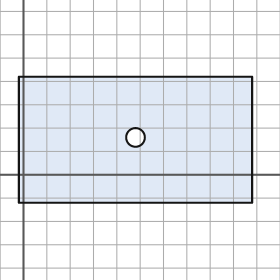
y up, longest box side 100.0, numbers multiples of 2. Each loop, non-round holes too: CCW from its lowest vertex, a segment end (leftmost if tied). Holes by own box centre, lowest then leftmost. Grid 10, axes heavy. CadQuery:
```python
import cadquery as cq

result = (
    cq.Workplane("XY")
    .moveTo(-2.0, -12.0)
    .lineTo(98.0, -12.0)
    .lineTo(98.0, 42.0)
    .lineTo(-2.0, 42.0)
    .close()
    .moveTo(48.0, 16.0)
    .circle(4.0)
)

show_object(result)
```